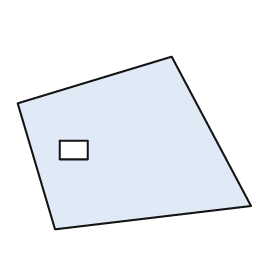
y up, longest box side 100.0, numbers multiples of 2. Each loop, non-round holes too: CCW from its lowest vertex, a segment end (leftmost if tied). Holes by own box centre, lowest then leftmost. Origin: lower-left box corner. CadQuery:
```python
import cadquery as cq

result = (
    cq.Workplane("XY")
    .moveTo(16.0, 0.0)
    .lineTo(100.0, 10.0)
    .lineTo(66.0, 74.0)
    .lineTo(0.0, 54.0)
    .close()
    .moveTo(18.0, 30.0)
    .lineTo(30.0, 30.0)
    .lineTo(30.0, 38.0)
    .lineTo(18.0, 38.0)
    .close()
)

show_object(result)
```